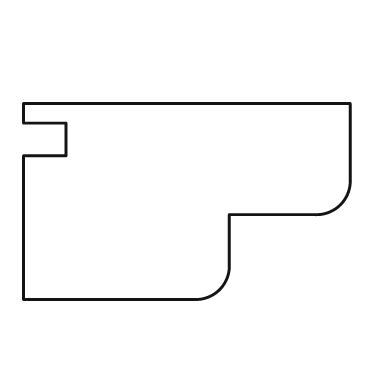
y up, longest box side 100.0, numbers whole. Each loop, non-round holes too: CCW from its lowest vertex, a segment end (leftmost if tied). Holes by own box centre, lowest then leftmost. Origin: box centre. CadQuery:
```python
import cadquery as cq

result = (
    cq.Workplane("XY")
    .moveTo(-50.0, -30.0)
    .lineTo(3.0, -30.0)
    .threePointArc((10.0, -27.0), (13.0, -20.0))
    .lineTo(13.0, -4.0)
    .lineTo(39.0, -4.0)
    .threePointArc((47.0, -1.0), (50.0, 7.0))
    .lineTo(50.0, 30.0)
    .lineTo(-50.0, 30.0)
    .lineTo(-50.0, 24.0)
    .lineTo(-37.0, 24.0)
    .lineTo(-37.0, 14.0)
    .lineTo(-50.0, 14.0)
    .close()
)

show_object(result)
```